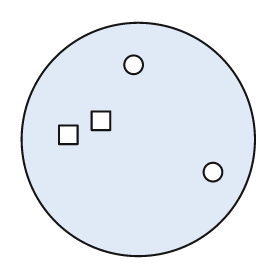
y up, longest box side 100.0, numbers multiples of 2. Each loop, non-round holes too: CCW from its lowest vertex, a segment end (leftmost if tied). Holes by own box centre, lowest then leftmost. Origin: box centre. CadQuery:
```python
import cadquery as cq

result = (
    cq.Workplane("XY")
    .moveTo(0.0, 0.0)
    .circle(50.0)
    .moveTo(32.0, -14.0)
    .circle(4.0)
    .moveTo(-34.0, -2.0)
    .lineTo(-26.0, -2.0)
    .lineTo(-26.0, 6.0)
    .lineTo(-34.0, 6.0)
    .close()
    .moveTo(-20.0, 4.0)
    .lineTo(-12.0, 4.0)
    .lineTo(-12.0, 12.0)
    .lineTo(-20.0, 12.0)
    .close()
    .moveTo(-2.0, 32.0)
    .circle(4.0)
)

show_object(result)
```